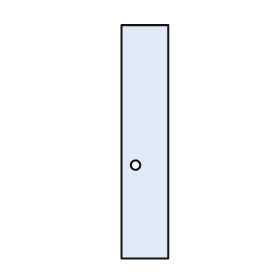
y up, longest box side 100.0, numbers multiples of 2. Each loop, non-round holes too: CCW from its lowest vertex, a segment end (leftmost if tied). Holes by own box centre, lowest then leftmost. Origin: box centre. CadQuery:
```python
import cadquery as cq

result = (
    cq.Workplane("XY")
    .moveTo(-10.0, -50.0)
    .lineTo(10.0, -50.0)
    .lineTo(10.0, 50.0)
    .lineTo(-10.0, 50.0)
    .close()
    .moveTo(-4.0, -10.0)
    .circle(2.0)
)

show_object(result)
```